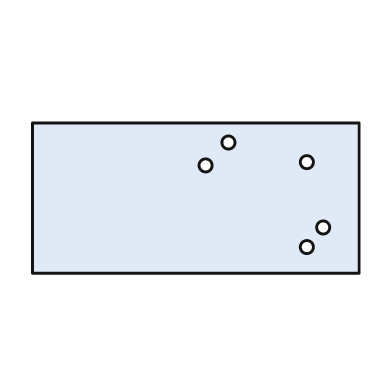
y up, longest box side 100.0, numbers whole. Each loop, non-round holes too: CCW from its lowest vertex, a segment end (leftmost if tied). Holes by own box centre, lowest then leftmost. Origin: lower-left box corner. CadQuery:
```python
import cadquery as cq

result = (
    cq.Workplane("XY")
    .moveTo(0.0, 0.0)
    .lineTo(100.0, 0.0)
    .lineTo(100.0, 46.0)
    .lineTo(0.0, 46.0)
    .close()
    .moveTo(84.0, 8.0)
    .circle(2.0)
    .moveTo(89.0, 14.0)
    .circle(2.0)
    .moveTo(53.0, 33.0)
    .circle(2.0)
    .moveTo(84.0, 34.0)
    .circle(2.0)
    .moveTo(60.0, 40.0)
    .circle(2.0)
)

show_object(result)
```